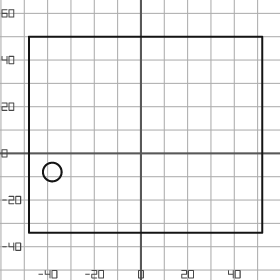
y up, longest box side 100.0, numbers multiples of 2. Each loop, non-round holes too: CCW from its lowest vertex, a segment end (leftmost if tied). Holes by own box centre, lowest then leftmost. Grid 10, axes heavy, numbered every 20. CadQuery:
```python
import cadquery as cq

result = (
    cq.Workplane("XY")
    .moveTo(-48.0, -34.0)
    .lineTo(52.0, -34.0)
    .lineTo(52.0, 50.0)
    .lineTo(-48.0, 50.0)
    .close()
    .moveTo(-38.0, -8.0)
    .circle(4.0)
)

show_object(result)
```